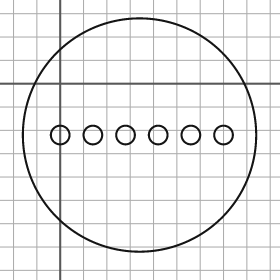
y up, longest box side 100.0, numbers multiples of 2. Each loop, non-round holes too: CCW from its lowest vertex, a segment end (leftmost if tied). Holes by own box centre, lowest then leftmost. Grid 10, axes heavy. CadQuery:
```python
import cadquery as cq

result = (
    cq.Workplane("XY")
    .moveTo(34.0, -22.0)
    .circle(50.0)
    .moveTo(0.0, -22.0)
    .circle(4.0)
    .moveTo(14.0, -22.0)
    .circle(4.0)
    .moveTo(28.0, -22.0)
    .circle(4.0)
    .moveTo(42.0, -22.0)
    .circle(4.0)
    .moveTo(56.0, -22.0)
    .circle(4.0)
    .moveTo(70.0, -22.0)
    .circle(4.0)
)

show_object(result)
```